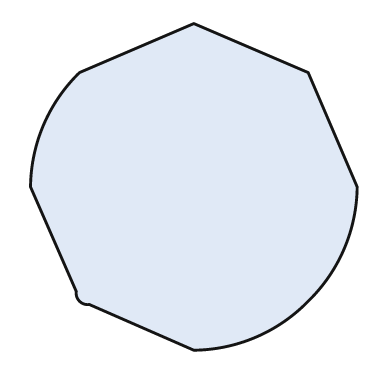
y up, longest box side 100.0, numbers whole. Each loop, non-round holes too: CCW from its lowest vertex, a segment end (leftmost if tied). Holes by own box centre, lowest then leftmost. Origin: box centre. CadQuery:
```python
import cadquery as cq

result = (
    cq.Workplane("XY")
    .moveTo(0.0, -50.0)
    .threePointArc((19.0, -46.0), (35.0, -35.0))
    .threePointArc((46.0, -19.0), (50.0, 0.0))
    .lineTo(35.0, 35.0)
    .lineTo(0.0, 50.0)
    .lineTo(-35.0, 35.0)
    .threePointArc((-46.0, 19.0), (-50.0, 0.0))
    .lineTo(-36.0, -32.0)
    .threePointArc((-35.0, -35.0), (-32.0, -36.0))
    .close()
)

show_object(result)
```